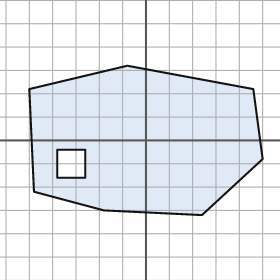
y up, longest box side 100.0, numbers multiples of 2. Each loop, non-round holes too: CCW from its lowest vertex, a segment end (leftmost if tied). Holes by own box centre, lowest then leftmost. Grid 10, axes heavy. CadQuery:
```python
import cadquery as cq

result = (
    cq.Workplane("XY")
    .moveTo(24.0, -32.0)
    .lineTo(50.0, -8.0)
    .lineTo(46.0, 22.0)
    .lineTo(-8.0, 32.0)
    .lineTo(-50.0, 22.0)
    .lineTo(-48.0, -22.0)
    .lineTo(-18.0, -30.0)
    .close()
    .moveTo(-38.0, -16.0)
    .lineTo(-26.0, -16.0)
    .lineTo(-26.0, -4.0)
    .lineTo(-38.0, -4.0)
    .close()
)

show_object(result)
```